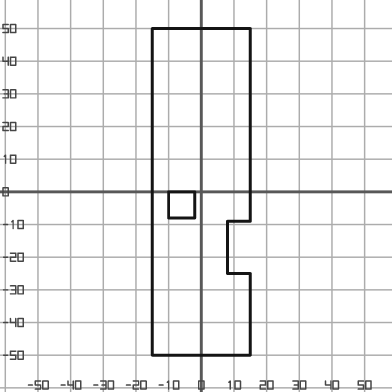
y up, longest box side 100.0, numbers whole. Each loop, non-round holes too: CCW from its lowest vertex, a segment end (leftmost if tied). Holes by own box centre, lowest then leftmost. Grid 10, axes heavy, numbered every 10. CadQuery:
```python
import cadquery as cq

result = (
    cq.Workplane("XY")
    .moveTo(-15.0, -50.0)
    .lineTo(15.0, -50.0)
    .lineTo(15.0, -25.0)
    .lineTo(8.0, -25.0)
    .lineTo(8.0, -9.0)
    .lineTo(15.0, -9.0)
    .lineTo(15.0, 50.0)
    .lineTo(-15.0, 50.0)
    .close()
    .moveTo(-10.0, -8.0)
    .lineTo(-2.0, -8.0)
    .lineTo(-2.0, 0.0)
    .lineTo(-10.0, 0.0)
    .close()
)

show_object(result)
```